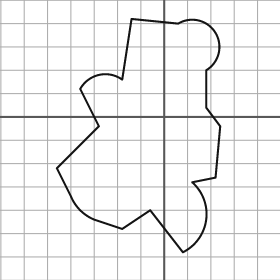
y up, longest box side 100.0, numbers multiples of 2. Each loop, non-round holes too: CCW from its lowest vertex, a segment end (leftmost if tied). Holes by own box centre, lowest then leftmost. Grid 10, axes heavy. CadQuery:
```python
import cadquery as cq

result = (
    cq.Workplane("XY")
    .moveTo(8.0, -58.0)
    .threePointArc((18.0, -44.0), (12.0, -28.0))
    .lineTo(22.0, -26.0)
    .lineTo(24.0, -4.0)
    .lineTo(18.0, 4.0)
    .lineTo(18.0, 20.0)
    .threePointArc((22.0, 36.0), (6.0, 40.0))
    .lineTo(-14.0, 42.0)
    .lineTo(-18.0, 16.0)
    .threePointArc((-28.0, 18.0), (-36.0, 12.0))
    .lineTo(-28.0, -4.0)
    .lineTo(-46.0, -22.0)
    .lineTo(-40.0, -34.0)
    .threePointArc((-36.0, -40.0), (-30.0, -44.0))
    .lineTo(-18.0, -48.0)
    .lineTo(-6.0, -40.0)
    .close()
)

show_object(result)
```